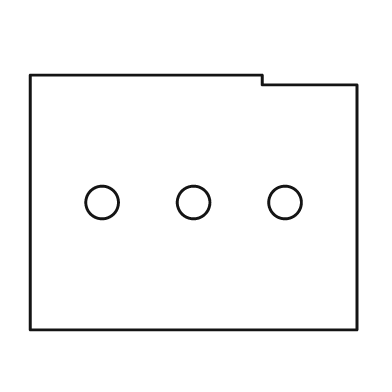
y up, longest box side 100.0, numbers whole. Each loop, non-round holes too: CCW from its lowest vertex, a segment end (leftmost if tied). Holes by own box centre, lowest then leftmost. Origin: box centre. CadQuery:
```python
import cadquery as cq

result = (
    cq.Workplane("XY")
    .moveTo(-50.0, -39.0)
    .lineTo(50.0, -39.0)
    .lineTo(50.0, 36.0)
    .lineTo(21.0, 36.0)
    .lineTo(21.0, 39.0)
    .lineTo(-50.0, 39.0)
    .close()
    .moveTo(-28.0, 0.0)
    .circle(5.0)
    .moveTo(0.0, 0.0)
    .circle(5.0)
    .moveTo(28.0, 0.0)
    .circle(5.0)
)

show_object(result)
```